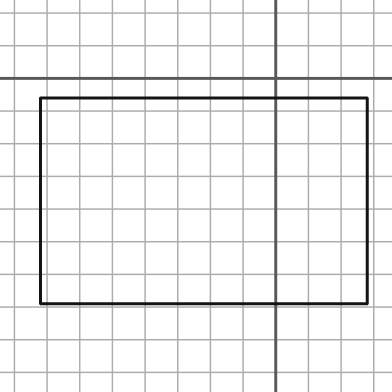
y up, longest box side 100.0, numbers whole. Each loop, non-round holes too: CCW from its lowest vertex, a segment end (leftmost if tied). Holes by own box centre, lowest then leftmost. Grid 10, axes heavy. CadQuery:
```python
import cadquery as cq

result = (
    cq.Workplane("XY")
    .moveTo(-72.0, -69.0)
    .lineTo(28.0, -69.0)
    .lineTo(28.0, -6.0)
    .lineTo(-72.0, -6.0)
    .close()
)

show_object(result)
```